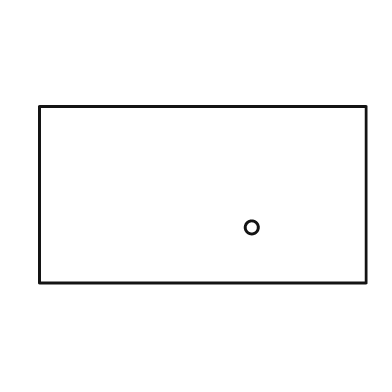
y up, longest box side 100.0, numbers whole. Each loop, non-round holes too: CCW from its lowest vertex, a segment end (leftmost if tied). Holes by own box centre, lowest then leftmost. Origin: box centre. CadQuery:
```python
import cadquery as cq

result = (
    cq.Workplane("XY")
    .moveTo(-50.0, -27.0)
    .lineTo(50.0, -27.0)
    .lineTo(50.0, 27.0)
    .lineTo(-50.0, 27.0)
    .close()
    .moveTo(15.0, -10.0)
    .circle(2.0)
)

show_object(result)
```